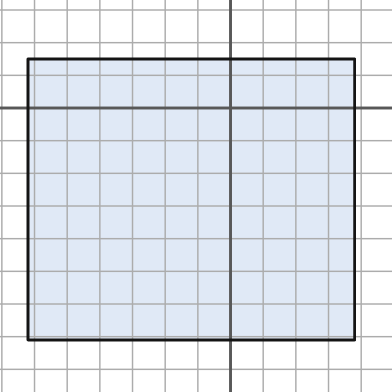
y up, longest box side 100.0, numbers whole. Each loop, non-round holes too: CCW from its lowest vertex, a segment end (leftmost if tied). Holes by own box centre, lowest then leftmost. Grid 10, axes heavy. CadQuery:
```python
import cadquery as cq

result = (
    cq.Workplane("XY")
    .moveTo(-62.0, -71.0)
    .lineTo(38.0, -71.0)
    .lineTo(38.0, 15.0)
    .lineTo(-62.0, 15.0)
    .close()
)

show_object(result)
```